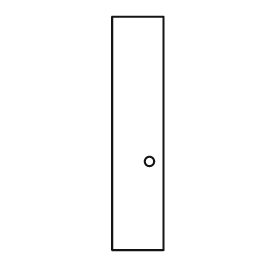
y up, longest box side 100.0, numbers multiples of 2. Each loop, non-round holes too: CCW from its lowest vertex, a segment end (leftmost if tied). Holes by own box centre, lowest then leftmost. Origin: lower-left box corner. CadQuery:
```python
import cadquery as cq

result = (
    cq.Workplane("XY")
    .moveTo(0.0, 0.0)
    .lineTo(22.0, 0.0)
    .lineTo(22.0, 100.0)
    .lineTo(0.0, 100.0)
    .close()
    .moveTo(16.0, 38.0)
    .circle(2.0)
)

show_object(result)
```